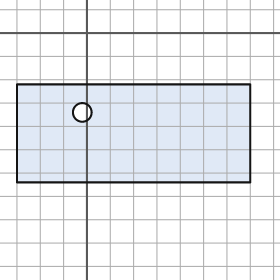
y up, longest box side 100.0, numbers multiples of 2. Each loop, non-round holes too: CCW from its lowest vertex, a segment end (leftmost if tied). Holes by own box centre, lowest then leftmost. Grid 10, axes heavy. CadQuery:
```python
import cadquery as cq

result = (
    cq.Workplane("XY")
    .moveTo(-30.0, -64.0)
    .lineTo(70.0, -64.0)
    .lineTo(70.0, -22.0)
    .lineTo(-30.0, -22.0)
    .close()
    .moveTo(-2.0, -34.0)
    .circle(4.0)
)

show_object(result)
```